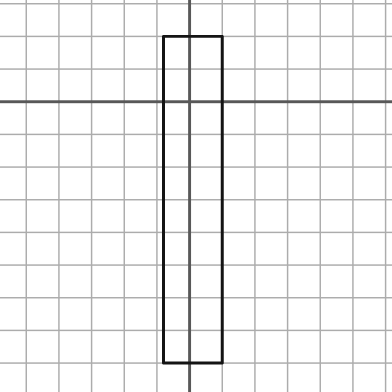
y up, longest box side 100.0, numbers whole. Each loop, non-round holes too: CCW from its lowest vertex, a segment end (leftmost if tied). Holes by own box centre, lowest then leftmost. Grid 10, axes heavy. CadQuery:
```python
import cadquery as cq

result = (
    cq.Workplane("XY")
    .moveTo(-8.0, -80.0)
    .lineTo(10.0, -80.0)
    .lineTo(10.0, 20.0)
    .lineTo(-8.0, 20.0)
    .close()
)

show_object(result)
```